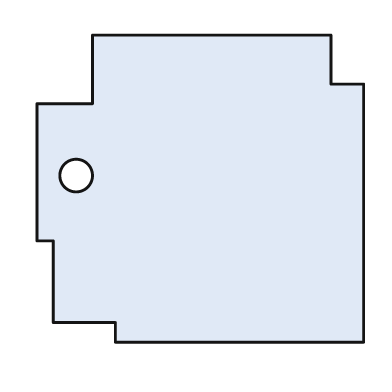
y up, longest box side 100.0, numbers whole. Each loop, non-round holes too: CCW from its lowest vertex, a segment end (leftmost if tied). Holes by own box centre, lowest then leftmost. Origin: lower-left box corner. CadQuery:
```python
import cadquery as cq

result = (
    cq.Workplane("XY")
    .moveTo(24.0, 0.0)
    .lineTo(100.0, 0.0)
    .lineTo(100.0, 79.0)
    .lineTo(90.0, 79.0)
    .lineTo(90.0, 94.0)
    .lineTo(17.0, 94.0)
    .lineTo(17.0, 73.0)
    .lineTo(0.0, 73.0)
    .lineTo(0.0, 31.0)
    .lineTo(5.0, 31.0)
    .lineTo(5.0, 6.0)
    .lineTo(24.0, 6.0)
    .close()
    .moveTo(12.0, 51.0)
    .circle(5.0)
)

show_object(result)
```